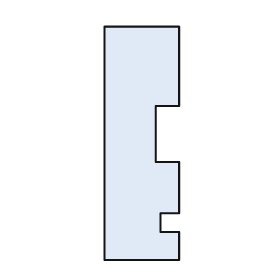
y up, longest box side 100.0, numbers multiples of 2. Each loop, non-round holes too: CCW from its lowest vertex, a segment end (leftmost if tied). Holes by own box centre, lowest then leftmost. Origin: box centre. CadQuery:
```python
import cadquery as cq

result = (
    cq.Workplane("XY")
    .moveTo(-16.0, -50.0)
    .lineTo(16.0, -50.0)
    .lineTo(16.0, -38.0)
    .lineTo(8.0, -38.0)
    .lineTo(8.0, -30.0)
    .lineTo(16.0, -30.0)
    .lineTo(16.0, -8.0)
    .lineTo(6.0, -8.0)
    .lineTo(6.0, 16.0)
    .lineTo(16.0, 16.0)
    .lineTo(16.0, 50.0)
    .lineTo(-16.0, 50.0)
    .close()
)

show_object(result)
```